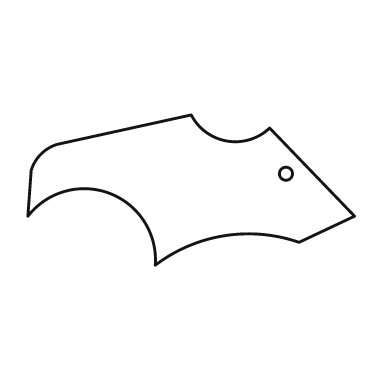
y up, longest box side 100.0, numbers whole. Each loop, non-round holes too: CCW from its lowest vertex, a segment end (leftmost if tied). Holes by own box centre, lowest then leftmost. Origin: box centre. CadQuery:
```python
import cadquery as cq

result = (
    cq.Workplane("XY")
    .moveTo(-11.0, -23.0)
    .threePointArc((10.0, -14.0), (33.0, -16.0))
    .lineTo(50.0, -8.0)
    .lineTo(24.0, 19.0)
    .threePointArc((11.0, 15.0), (0.0, 23.0))
    .lineTo(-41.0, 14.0)
    .threePointArc((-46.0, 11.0), (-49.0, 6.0))
    .lineTo(-50.0, -8.0)
    .threePointArc((-25.0, -1.0), (-11.0, -23.0))
    .close()
    .moveTo(29.0, 5.0)
    .circle(2.0)
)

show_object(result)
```